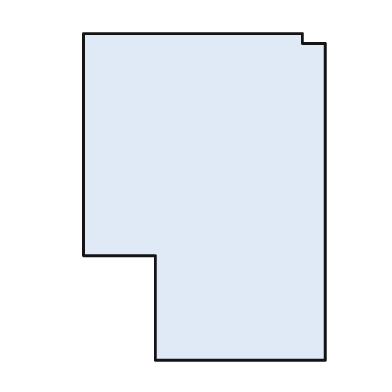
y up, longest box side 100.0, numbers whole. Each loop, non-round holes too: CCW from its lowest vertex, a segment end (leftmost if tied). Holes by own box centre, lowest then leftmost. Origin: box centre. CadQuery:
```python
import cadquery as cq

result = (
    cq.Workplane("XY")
    .moveTo(-15.0, -50.0)
    .lineTo(37.0, -50.0)
    .lineTo(37.0, 47.0)
    .lineTo(30.0, 47.0)
    .lineTo(30.0, 50.0)
    .lineTo(-37.0, 50.0)
    .lineTo(-37.0, -18.0)
    .lineTo(-15.0, -18.0)
    .close()
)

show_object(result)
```